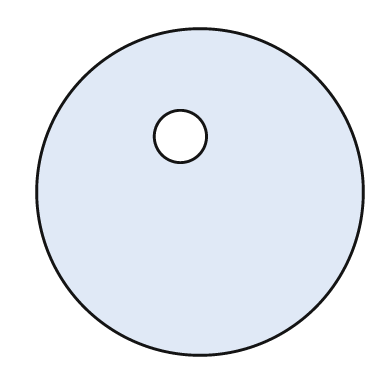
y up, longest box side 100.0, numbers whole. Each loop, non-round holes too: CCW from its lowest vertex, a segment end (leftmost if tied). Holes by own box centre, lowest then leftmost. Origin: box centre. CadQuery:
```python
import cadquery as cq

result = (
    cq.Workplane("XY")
    .moveTo(0.0, 0.0)
    .circle(50.0)
    .moveTo(-6.0, 17.0)
    .circle(8.0)
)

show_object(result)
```